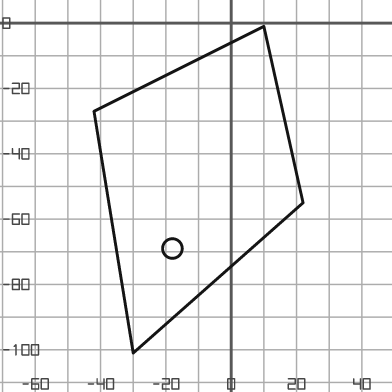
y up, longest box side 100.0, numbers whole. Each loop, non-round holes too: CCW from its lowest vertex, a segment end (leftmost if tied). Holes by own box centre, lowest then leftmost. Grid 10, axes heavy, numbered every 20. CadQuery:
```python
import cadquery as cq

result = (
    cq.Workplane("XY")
    .moveTo(-30.0, -101.0)
    .lineTo(22.0, -55.0)
    .lineTo(10.0, -1.0)
    .lineTo(-42.0, -27.0)
    .close()
    .moveTo(-18.0, -69.0)
    .circle(3.0)
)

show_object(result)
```